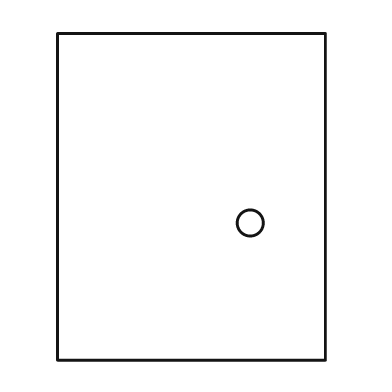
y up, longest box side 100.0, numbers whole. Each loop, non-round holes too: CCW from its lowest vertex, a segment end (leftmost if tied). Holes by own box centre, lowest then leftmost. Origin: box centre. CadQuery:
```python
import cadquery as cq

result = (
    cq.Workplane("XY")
    .moveTo(-41.0, -50.0)
    .lineTo(41.0, -50.0)
    .lineTo(41.0, 50.0)
    .lineTo(-41.0, 50.0)
    .close()
    .moveTo(18.0, -8.0)
    .circle(4.0)
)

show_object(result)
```